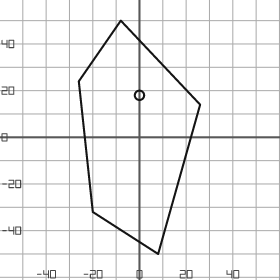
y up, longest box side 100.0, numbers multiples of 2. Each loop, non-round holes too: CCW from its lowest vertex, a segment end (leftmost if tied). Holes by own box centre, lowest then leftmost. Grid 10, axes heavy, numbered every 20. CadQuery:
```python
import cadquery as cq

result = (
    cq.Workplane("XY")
    .moveTo(8.0, -50.0)
    .lineTo(26.0, 14.0)
    .lineTo(-8.0, 50.0)
    .lineTo(-26.0, 24.0)
    .lineTo(-20.0, -32.0)
    .close()
    .moveTo(0.0, 18.0)
    .circle(2.0)
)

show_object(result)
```